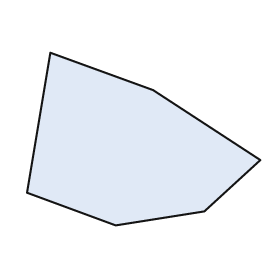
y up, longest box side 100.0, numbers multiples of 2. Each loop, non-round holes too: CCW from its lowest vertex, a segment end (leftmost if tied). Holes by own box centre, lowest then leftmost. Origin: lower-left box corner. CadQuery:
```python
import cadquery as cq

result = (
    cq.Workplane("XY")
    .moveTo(38.0, 0.0)
    .lineTo(76.0, 6.0)
    .lineTo(100.0, 28.0)
    .lineTo(54.0, 58.0)
    .lineTo(10.0, 74.0)
    .lineTo(0.0, 14.0)
    .close()
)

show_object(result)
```